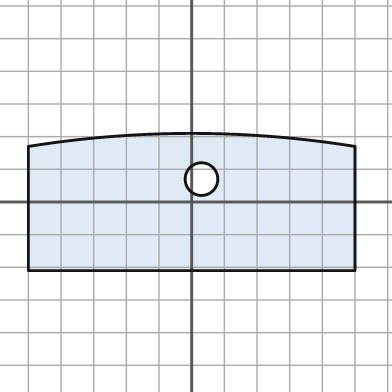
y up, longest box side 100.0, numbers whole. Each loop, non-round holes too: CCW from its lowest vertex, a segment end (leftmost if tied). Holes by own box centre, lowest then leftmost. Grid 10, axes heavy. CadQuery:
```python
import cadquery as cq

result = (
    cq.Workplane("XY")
    .moveTo(-50.0, -21.0)
    .lineTo(50.0, -21.0)
    .lineTo(50.0, 17.0)
    .threePointArc((0.0, 21.0), (-50.0, 17.0))
    .close()
    .moveTo(3.0, 7.0)
    .circle(5.0)
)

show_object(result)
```